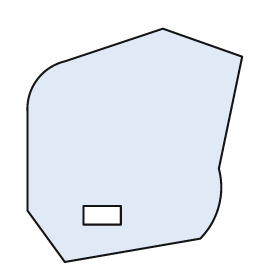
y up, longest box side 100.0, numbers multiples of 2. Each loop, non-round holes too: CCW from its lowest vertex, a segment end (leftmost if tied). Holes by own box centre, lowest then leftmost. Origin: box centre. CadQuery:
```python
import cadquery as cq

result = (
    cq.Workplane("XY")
    .moveTo(-30.0, -50.0)
    .lineTo(28.0, -40.0)
    .threePointArc((36.0, -26.0), (36.0, -10.0))
    .lineTo(46.0, 38.0)
    .lineTo(12.0, 50.0)
    .lineTo(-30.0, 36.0)
    .threePointArc((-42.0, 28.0), (-46.0, 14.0))
    .lineTo(-46.0, -28.0)
    .close()
    .moveTo(-22.0, -34.0)
    .lineTo(-6.0, -34.0)
    .lineTo(-6.0, -26.0)
    .lineTo(-22.0, -26.0)
    .close()
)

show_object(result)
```